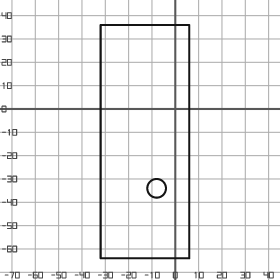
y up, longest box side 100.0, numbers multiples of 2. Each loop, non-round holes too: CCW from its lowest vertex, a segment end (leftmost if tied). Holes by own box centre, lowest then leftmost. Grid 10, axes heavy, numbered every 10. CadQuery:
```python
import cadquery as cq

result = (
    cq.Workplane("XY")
    .moveTo(-32.0, -64.0)
    .lineTo(6.0, -64.0)
    .lineTo(6.0, 36.0)
    .lineTo(-32.0, 36.0)
    .close()
    .moveTo(-8.0, -34.0)
    .circle(4.0)
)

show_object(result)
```